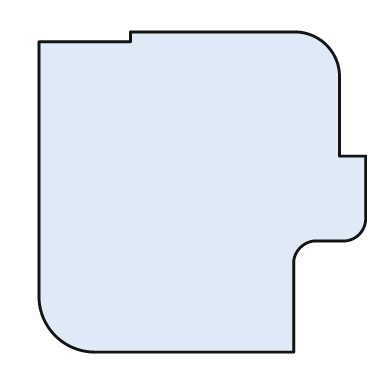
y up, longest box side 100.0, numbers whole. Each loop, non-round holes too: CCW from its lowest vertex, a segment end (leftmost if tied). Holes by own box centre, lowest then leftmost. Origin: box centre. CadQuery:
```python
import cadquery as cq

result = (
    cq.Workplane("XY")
    .moveTo(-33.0, -49.0)
    .lineTo(28.0, -49.0)
    .lineTo(28.0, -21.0)
    .threePointArc((30.0, -17.0), (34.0, -15.0))
    .lineTo(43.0, -15.0)
    .threePointArc((48.0, -13.0), (50.0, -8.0))
    .lineTo(50.0, 11.0)
    .lineTo(42.0, 11.0)
    .lineTo(42.0, 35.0)
    .threePointArc((38.0, 45.0), (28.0, 49.0))
    .lineTo(-22.0, 49.0)
    .lineTo(-22.0, 46.0)
    .lineTo(-50.0, 46.0)
    .lineTo(-50.0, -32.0)
    .threePointArc((-45.0, -44.0), (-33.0, -49.0))
    .close()
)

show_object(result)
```